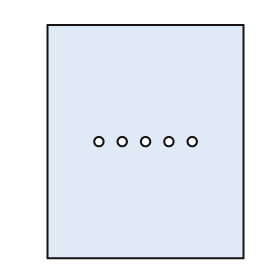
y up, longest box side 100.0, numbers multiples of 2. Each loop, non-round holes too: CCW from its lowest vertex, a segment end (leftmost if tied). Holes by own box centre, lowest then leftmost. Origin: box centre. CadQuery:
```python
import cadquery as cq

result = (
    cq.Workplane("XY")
    .moveTo(-42.0, -50.0)
    .lineTo(42.0, -50.0)
    .lineTo(42.0, 50.0)
    .lineTo(-42.0, 50.0)
    .close()
    .moveTo(-20.0, 0.0)
    .circle(2.0)
    .moveTo(-10.0, 0.0)
    .circle(2.0)
    .moveTo(0.0, 0.0)
    .circle(2.0)
    .moveTo(10.0, 0.0)
    .circle(2.0)
    .moveTo(20.0, 0.0)
    .circle(2.0)
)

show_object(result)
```